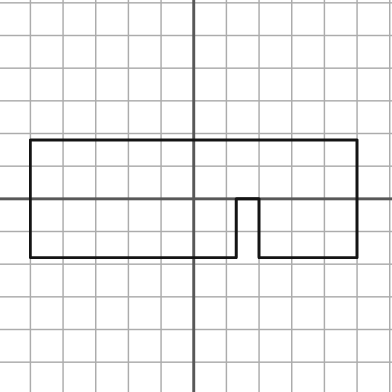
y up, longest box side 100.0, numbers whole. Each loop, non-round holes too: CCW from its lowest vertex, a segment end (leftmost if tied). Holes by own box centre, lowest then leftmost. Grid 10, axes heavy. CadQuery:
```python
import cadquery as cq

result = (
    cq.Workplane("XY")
    .moveTo(-50.0, -18.0)
    .lineTo(13.0, -18.0)
    .lineTo(13.0, 0.0)
    .lineTo(20.0, 0.0)
    .lineTo(20.0, -18.0)
    .lineTo(50.0, -18.0)
    .lineTo(50.0, 18.0)
    .lineTo(-50.0, 18.0)
    .close()
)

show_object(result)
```